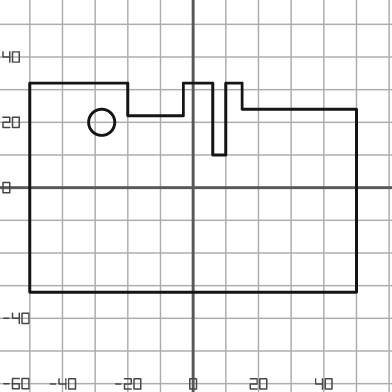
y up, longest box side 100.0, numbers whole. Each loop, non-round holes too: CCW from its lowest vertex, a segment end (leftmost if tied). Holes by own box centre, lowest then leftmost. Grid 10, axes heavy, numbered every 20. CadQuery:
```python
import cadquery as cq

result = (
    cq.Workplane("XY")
    .moveTo(-50.0, -32.0)
    .lineTo(50.0, -32.0)
    .lineTo(50.0, 24.0)
    .lineTo(15.0, 24.0)
    .lineTo(15.0, 32.0)
    .lineTo(10.0, 32.0)
    .lineTo(10.0, 10.0)
    .lineTo(6.0, 10.0)
    .lineTo(6.0, 32.0)
    .lineTo(-3.0, 32.0)
    .lineTo(-3.0, 22.0)
    .lineTo(-20.0, 22.0)
    .lineTo(-20.0, 32.0)
    .lineTo(-50.0, 32.0)
    .close()
    .moveTo(-28.0, 20.0)
    .circle(4.0)
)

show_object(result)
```